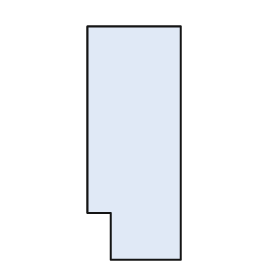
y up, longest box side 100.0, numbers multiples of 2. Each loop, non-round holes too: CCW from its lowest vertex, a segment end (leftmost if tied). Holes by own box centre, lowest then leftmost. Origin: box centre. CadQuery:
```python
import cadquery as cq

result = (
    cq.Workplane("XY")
    .moveTo(-10.0, -50.0)
    .lineTo(20.0, -50.0)
    .lineTo(20.0, 50.0)
    .lineTo(-20.0, 50.0)
    .lineTo(-20.0, -30.0)
    .lineTo(-10.0, -30.0)
    .close()
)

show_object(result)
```